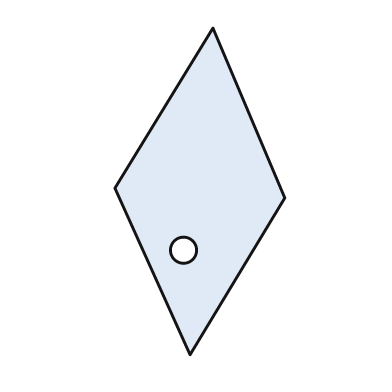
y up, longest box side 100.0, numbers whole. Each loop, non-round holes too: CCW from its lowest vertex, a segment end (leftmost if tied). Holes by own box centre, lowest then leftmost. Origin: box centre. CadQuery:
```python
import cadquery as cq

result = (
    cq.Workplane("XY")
    .moveTo(-3.0, -50.0)
    .lineTo(26.0, -2.0)
    .lineTo(4.0, 50.0)
    .lineTo(-26.0, 1.0)
    .close()
    .moveTo(-5.0, -18.0)
    .circle(4.0)
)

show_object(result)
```